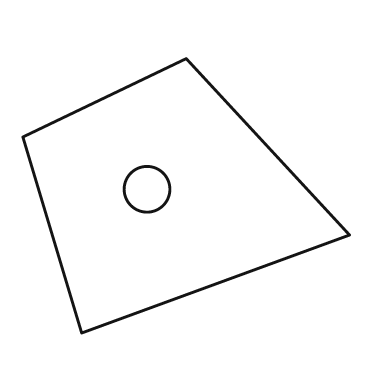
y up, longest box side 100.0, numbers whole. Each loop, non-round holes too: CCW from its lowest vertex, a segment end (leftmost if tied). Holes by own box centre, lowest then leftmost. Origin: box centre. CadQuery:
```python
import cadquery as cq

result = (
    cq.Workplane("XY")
    .moveTo(-32.0, -42.0)
    .lineTo(50.0, -12.0)
    .lineTo(0.0, 42.0)
    .lineTo(-50.0, 18.0)
    .close()
    .moveTo(-12.0, 2.0)
    .circle(7.0)
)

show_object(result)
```